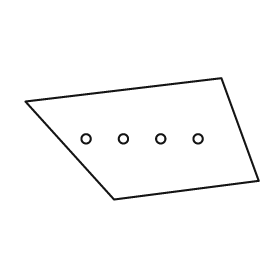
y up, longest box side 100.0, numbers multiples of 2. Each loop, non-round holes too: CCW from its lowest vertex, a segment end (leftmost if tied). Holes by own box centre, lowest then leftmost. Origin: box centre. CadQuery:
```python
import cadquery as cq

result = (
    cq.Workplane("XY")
    .moveTo(-12.0, -26.0)
    .lineTo(50.0, -18.0)
    .lineTo(34.0, 26.0)
    .lineTo(-50.0, 16.0)
    .close()
    .moveTo(-24.0, 0.0)
    .circle(2.0)
    .moveTo(-8.0, 0.0)
    .circle(2.0)
    .moveTo(8.0, 0.0)
    .circle(2.0)
    .moveTo(24.0, 0.0)
    .circle(2.0)
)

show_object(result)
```